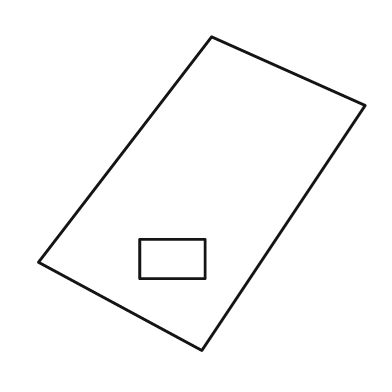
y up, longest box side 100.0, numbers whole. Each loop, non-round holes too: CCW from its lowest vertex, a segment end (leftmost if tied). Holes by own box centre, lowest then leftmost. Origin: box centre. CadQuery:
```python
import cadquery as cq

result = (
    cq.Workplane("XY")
    .moveTo(0.0, -48.0)
    .lineTo(50.0, 27.0)
    .lineTo(3.0, 48.0)
    .lineTo(-50.0, -21.0)
    .close()
    .moveTo(-19.0, -26.0)
    .lineTo(1.0, -26.0)
    .lineTo(1.0, -14.0)
    .lineTo(-19.0, -14.0)
    .close()
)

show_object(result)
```